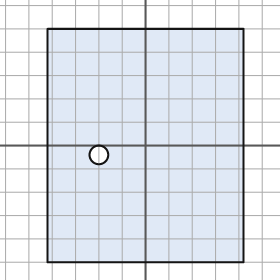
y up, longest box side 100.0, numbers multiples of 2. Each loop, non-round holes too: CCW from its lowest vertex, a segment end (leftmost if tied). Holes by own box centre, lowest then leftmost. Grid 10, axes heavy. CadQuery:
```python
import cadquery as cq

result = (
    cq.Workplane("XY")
    .moveTo(-42.0, -50.0)
    .lineTo(42.0, -50.0)
    .lineTo(42.0, 50.0)
    .lineTo(-42.0, 50.0)
    .close()
    .moveTo(-20.0, -4.0)
    .circle(4.0)
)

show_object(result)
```